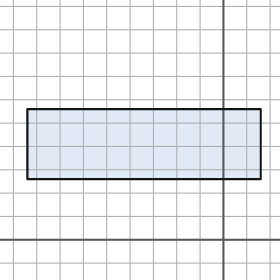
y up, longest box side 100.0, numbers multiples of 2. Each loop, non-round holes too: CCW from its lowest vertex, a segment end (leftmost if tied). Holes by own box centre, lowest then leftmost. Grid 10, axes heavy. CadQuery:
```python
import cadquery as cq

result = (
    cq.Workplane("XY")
    .moveTo(-84.0, 26.0)
    .lineTo(16.0, 26.0)
    .lineTo(16.0, 56.0)
    .lineTo(-84.0, 56.0)
    .close()
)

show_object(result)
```